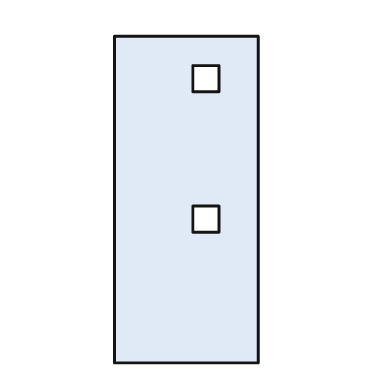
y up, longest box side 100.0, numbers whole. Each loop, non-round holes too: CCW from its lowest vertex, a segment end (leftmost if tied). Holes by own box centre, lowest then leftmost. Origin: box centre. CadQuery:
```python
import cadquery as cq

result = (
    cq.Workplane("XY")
    .moveTo(-22.0, -50.0)
    .lineTo(22.0, -50.0)
    .lineTo(22.0, 50.0)
    .lineTo(-22.0, 50.0)
    .close()
    .moveTo(2.0, -10.0)
    .lineTo(10.0, -10.0)
    .lineTo(10.0, -2.0)
    .lineTo(2.0, -2.0)
    .close()
    .moveTo(2.0, 33.0)
    .lineTo(10.0, 33.0)
    .lineTo(10.0, 41.0)
    .lineTo(2.0, 41.0)
    .close()
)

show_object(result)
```